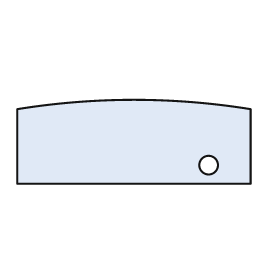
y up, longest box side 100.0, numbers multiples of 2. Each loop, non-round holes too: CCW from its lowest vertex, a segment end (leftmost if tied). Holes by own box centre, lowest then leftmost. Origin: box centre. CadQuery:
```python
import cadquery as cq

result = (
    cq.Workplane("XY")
    .moveTo(-50.0, -18.0)
    .lineTo(50.0, -18.0)
    .lineTo(50.0, 14.0)
    .threePointArc((0.0, 18.0), (-50.0, 14.0))
    .close()
    .moveTo(32.0, -10.0)
    .circle(4.0)
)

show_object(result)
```